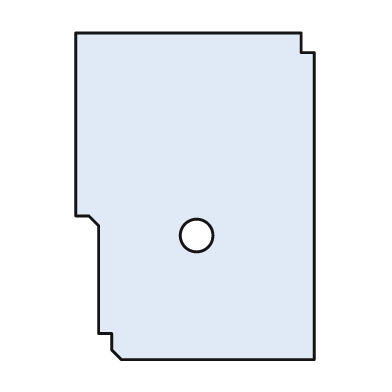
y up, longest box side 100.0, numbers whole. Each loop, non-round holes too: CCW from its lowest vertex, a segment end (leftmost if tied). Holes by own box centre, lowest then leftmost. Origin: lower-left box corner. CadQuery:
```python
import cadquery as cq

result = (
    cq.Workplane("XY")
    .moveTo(14.0, 0.0)
    .lineTo(73.0, 0.0)
    .lineTo(73.0, 94.0)
    .lineTo(69.0, 94.0)
    .lineTo(69.0, 100.0)
    .lineTo(0.0, 100.0)
    .lineTo(0.0, 44.0)
    .lineTo(4.0, 44.0)
    .lineTo(7.0, 41.0)
    .lineTo(7.0, 8.0)
    .lineTo(11.0, 8.0)
    .lineTo(11.0, 3.0)
    .close()
    .moveTo(37.0, 38.0)
    .circle(5.0)
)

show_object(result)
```